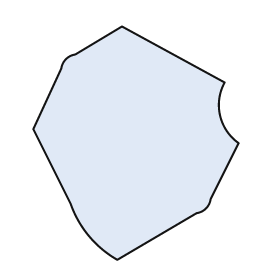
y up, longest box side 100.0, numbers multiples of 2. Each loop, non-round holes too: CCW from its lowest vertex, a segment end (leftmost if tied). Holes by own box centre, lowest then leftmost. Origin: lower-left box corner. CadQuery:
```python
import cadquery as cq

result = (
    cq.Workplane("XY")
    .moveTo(36.0, 0.0)
    .lineTo(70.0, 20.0)
    .threePointArc((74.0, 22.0), (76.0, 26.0))
    .lineTo(88.0, 50.0)
    .threePointArc((80.0, 62.0), (82.0, 76.0))
    .lineTo(38.0, 100.0)
    .lineTo(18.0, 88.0)
    .threePointArc((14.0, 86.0), (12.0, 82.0))
    .lineTo(0.0, 56.0)
    .lineTo(16.0, 24.0)
    .threePointArc((24.0, 10.0), (36.0, 0.0))
    .close()
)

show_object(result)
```